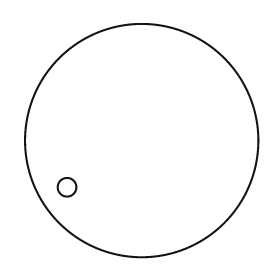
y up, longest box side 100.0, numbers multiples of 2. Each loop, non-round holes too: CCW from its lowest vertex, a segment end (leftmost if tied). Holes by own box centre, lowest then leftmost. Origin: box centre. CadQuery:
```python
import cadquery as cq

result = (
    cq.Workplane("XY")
    .moveTo(0.0, 0.0)
    .circle(50.0)
    .moveTo(-32.0, -20.0)
    .circle(4.0)
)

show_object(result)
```